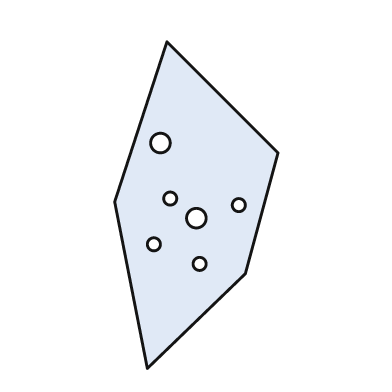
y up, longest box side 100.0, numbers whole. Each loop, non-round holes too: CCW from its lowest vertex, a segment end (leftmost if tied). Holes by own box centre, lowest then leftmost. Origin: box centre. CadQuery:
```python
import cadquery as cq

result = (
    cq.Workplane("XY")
    .moveTo(-15.0, -50.0)
    .lineTo(15.0, -21.0)
    .lineTo(25.0, 16.0)
    .lineTo(-9.0, 50.0)
    .lineTo(-25.0, 1.0)
    .close()
    .moveTo(1.0, -18.0)
    .circle(2.0)
    .moveTo(-13.0, -12.0)
    .circle(2.0)
    .moveTo(0.0, -4.0)
    .circle(3.0)
    .moveTo(13.0, 0.0)
    .circle(2.0)
    .moveTo(-8.0, 2.0)
    .circle(2.0)
    .moveTo(-11.0, 19.0)
    .circle(3.0)
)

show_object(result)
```